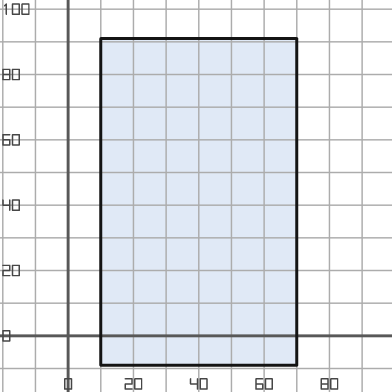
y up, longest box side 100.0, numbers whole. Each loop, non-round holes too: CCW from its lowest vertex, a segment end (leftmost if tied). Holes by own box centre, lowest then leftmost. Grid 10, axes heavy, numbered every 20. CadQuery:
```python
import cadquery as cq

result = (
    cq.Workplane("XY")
    .moveTo(10.0, -9.0)
    .lineTo(70.0, -9.0)
    .lineTo(70.0, 91.0)
    .lineTo(10.0, 91.0)
    .close()
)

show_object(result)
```